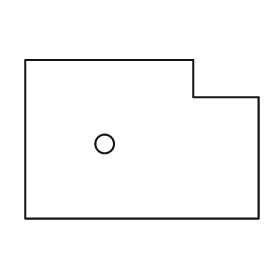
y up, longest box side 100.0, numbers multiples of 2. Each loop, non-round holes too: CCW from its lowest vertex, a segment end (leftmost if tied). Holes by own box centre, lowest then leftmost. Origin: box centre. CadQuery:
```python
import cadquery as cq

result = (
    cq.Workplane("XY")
    .moveTo(-50.0, -34.0)
    .lineTo(50.0, -34.0)
    .lineTo(50.0, 18.0)
    .lineTo(22.0, 18.0)
    .lineTo(22.0, 34.0)
    .lineTo(-50.0, 34.0)
    .close()
    .moveTo(-16.0, -2.0)
    .circle(4.0)
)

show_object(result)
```